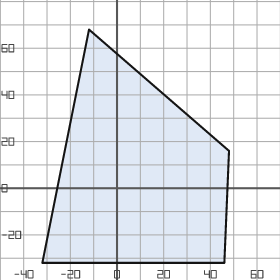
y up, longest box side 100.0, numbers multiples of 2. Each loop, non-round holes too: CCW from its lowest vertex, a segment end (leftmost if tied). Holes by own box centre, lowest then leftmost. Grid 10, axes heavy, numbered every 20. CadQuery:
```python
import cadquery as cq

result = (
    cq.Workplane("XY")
    .moveTo(-32.0, -32.0)
    .lineTo(46.0, -32.0)
    .lineTo(48.0, 16.0)
    .lineTo(-12.0, 68.0)
    .close()
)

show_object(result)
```